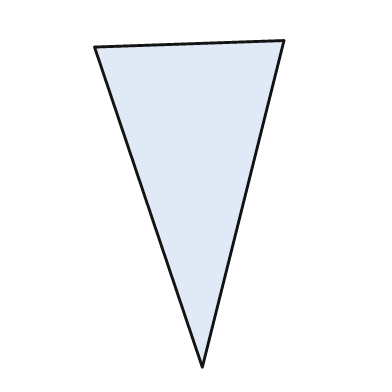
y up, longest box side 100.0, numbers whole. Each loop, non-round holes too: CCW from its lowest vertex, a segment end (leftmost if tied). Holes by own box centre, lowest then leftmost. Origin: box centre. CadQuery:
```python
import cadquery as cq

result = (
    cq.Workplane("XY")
    .moveTo(4.0, -50.0)
    .lineTo(29.0, 50.0)
    .lineTo(-29.0, 48.0)
    .close()
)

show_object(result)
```